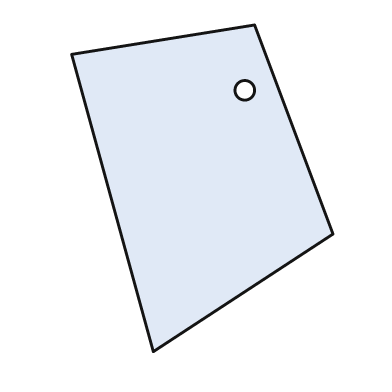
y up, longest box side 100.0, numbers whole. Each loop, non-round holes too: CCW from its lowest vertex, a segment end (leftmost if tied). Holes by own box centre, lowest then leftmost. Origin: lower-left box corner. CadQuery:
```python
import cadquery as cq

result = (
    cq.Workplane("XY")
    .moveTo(25.0, 0.0)
    .lineTo(80.0, 36.0)
    .lineTo(56.0, 100.0)
    .lineTo(0.0, 91.0)
    .close()
    .moveTo(53.0, 80.0)
    .circle(3.0)
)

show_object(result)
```